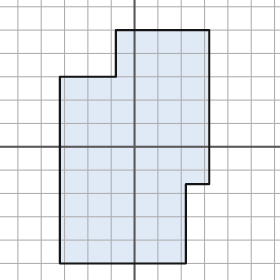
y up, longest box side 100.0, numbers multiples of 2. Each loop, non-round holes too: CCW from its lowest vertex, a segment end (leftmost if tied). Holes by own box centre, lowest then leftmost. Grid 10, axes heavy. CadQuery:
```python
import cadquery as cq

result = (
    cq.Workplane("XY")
    .moveTo(-32.0, -50.0)
    .lineTo(22.0, -50.0)
    .lineTo(22.0, -16.0)
    .lineTo(32.0, -16.0)
    .lineTo(32.0, 50.0)
    .lineTo(-8.0, 50.0)
    .lineTo(-8.0, 30.0)
    .lineTo(-32.0, 30.0)
    .close()
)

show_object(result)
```